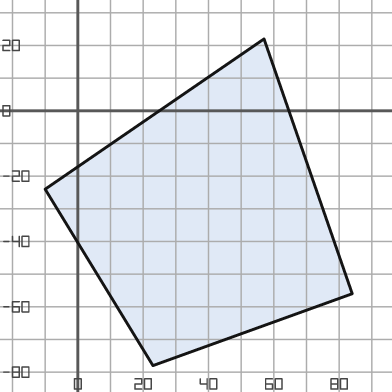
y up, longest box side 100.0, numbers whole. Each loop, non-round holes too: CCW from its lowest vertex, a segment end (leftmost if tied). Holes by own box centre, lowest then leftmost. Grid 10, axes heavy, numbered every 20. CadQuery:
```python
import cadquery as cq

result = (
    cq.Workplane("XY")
    .moveTo(23.0, -78.0)
    .lineTo(84.0, -56.0)
    .lineTo(57.0, 22.0)
    .lineTo(-10.0, -24.0)
    .close()
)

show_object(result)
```